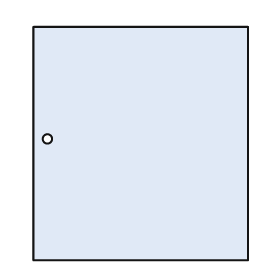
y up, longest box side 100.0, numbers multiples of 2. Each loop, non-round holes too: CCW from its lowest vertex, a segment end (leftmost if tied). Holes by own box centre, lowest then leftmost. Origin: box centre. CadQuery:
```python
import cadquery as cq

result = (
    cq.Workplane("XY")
    .moveTo(-46.0, -50.0)
    .lineTo(46.0, -50.0)
    .lineTo(46.0, 50.0)
    .lineTo(-46.0, 50.0)
    .close()
    .moveTo(-40.0, 2.0)
    .circle(2.0)
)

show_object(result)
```